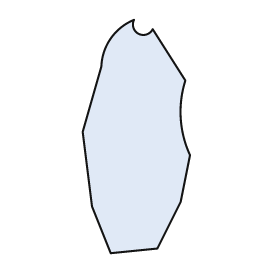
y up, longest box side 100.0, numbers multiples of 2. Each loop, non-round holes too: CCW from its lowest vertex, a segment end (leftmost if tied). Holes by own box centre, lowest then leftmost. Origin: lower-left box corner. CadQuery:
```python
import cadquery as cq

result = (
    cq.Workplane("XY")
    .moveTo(12.0, 0.0)
    .lineTo(32.0, 2.0)
    .lineTo(42.0, 22.0)
    .lineTo(46.0, 42.0)
    .threePointArc((42.0, 58.0), (44.0, 74.0))
    .lineTo(30.0, 96.0)
    .threePointArc((24.0, 94.0), (22.0, 100.0))
    .threePointArc((12.0, 92.0), (8.0, 80.0))
    .lineTo(0.0, 52.0)
    .lineTo(4.0, 20.0)
    .close()
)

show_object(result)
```